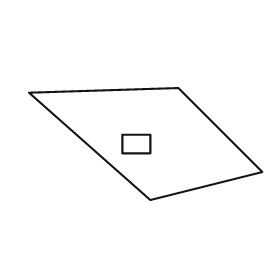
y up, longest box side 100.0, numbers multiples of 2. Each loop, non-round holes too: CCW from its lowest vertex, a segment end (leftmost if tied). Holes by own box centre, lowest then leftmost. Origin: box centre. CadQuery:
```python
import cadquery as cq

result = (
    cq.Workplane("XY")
    .moveTo(2.0, -24.0)
    .lineTo(50.0, -12.0)
    .lineTo(14.0, 24.0)
    .lineTo(-50.0, 22.0)
    .close()
    .moveTo(-10.0, -4.0)
    .lineTo(2.0, -4.0)
    .lineTo(2.0, 4.0)
    .lineTo(-10.0, 4.0)
    .close()
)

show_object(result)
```